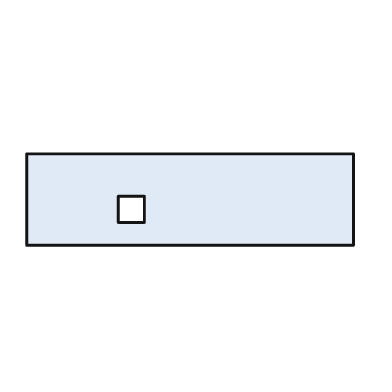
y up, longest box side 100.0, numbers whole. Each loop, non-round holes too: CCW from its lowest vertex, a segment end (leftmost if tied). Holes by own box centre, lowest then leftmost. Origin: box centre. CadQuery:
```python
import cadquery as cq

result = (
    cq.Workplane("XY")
    .moveTo(-50.0, -14.0)
    .lineTo(50.0, -14.0)
    .lineTo(50.0, 14.0)
    .lineTo(-50.0, 14.0)
    .close()
    .moveTo(-22.0, -7.0)
    .lineTo(-14.0, -7.0)
    .lineTo(-14.0, 1.0)
    .lineTo(-22.0, 1.0)
    .close()
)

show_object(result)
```